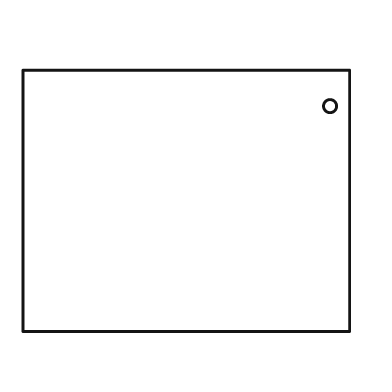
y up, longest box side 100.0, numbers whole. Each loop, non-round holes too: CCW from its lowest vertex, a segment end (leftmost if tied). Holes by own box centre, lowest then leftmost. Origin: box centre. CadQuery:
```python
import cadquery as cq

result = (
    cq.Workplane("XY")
    .moveTo(-50.0, -40.0)
    .lineTo(50.0, -40.0)
    .lineTo(50.0, 40.0)
    .lineTo(-50.0, 40.0)
    .close()
    .moveTo(44.0, 29.0)
    .circle(2.0)
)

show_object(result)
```